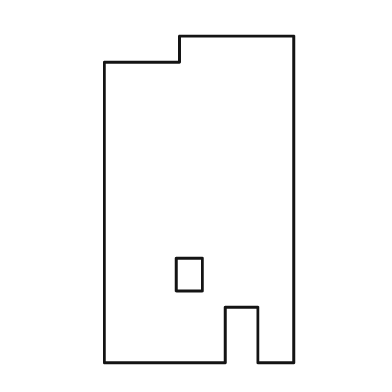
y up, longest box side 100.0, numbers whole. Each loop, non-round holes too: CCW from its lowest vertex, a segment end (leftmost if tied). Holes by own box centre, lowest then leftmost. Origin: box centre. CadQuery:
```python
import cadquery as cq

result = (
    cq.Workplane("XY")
    .moveTo(-29.0, -50.0)
    .lineTo(8.0, -50.0)
    .lineTo(8.0, -33.0)
    .lineTo(18.0, -33.0)
    .lineTo(18.0, -50.0)
    .lineTo(29.0, -50.0)
    .lineTo(29.0, 50.0)
    .lineTo(-6.0, 50.0)
    .lineTo(-6.0, 42.0)
    .lineTo(-29.0, 42.0)
    .close()
    .moveTo(-7.0, -28.0)
    .lineTo(1.0, -28.0)
    .lineTo(1.0, -18.0)
    .lineTo(-7.0, -18.0)
    .close()
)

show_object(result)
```